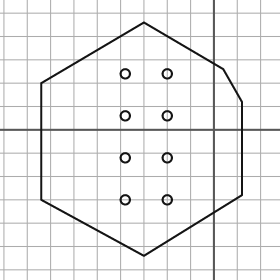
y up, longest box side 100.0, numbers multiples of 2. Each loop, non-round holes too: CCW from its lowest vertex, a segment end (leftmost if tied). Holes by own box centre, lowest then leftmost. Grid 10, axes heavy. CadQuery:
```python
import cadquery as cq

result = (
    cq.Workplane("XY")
    .moveTo(-30.0, -54.0)
    .lineTo(12.0, -28.0)
    .lineTo(12.0, 12.0)
    .lineTo(4.0, 26.0)
    .lineTo(-30.0, 46.0)
    .lineTo(-74.0, 20.0)
    .lineTo(-74.0, -30.0)
    .close()
    .moveTo(-38.0, -30.0)
    .circle(2.0)
    .moveTo(-20.0, -30.0)
    .circle(2.0)
    .moveTo(-38.0, -12.0)
    .circle(2.0)
    .moveTo(-20.0, -12.0)
    .circle(2.0)
    .moveTo(-38.0, 6.0)
    .circle(2.0)
    .moveTo(-20.0, 6.0)
    .circle(2.0)
    .moveTo(-38.0, 24.0)
    .circle(2.0)
    .moveTo(-20.0, 24.0)
    .circle(2.0)
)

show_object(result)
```